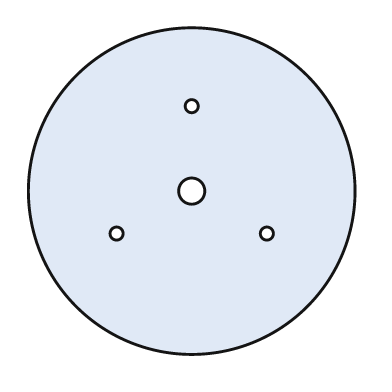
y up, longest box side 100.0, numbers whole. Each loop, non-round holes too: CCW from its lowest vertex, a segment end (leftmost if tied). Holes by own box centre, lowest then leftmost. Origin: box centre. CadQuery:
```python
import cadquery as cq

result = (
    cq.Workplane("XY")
    .moveTo(0.0, 0.0)
    .circle(50.0)
    .moveTo(-23.0, -13.0)
    .circle(2.0)
    .moveTo(23.0, -13.0)
    .circle(2.0)
    .moveTo(0.0, 0.0)
    .circle(4.0)
    .moveTo(0.0, 26.0)
    .circle(2.0)
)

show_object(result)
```